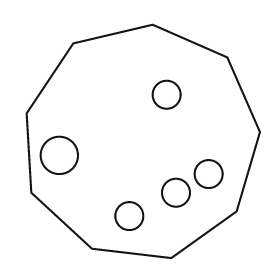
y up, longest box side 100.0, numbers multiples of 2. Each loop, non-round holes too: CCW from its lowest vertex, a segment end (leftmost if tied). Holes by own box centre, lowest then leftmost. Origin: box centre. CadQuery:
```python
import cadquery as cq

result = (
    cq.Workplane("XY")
    .moveTo(12.0, -50.0)
    .lineTo(40.0, -30.0)
    .lineTo(50.0, 4.0)
    .lineTo(36.0, 36.0)
    .lineTo(4.0, 50.0)
    .lineTo(-30.0, 42.0)
    .lineTo(-50.0, 12.0)
    .lineTo(-48.0, -22.0)
    .lineTo(-22.0, -46.0)
    .close()
    .moveTo(-6.0, -32.0)
    .circle(6.0)
    .moveTo(14.0, -22.0)
    .circle(6.0)
    .moveTo(28.0, -14.0)
    .circle(6.0)
    .moveTo(-36.0, -6.0)
    .circle(8.0)
    .moveTo(10.0, 20.0)
    .circle(6.0)
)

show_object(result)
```